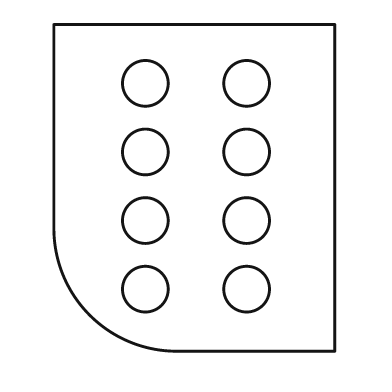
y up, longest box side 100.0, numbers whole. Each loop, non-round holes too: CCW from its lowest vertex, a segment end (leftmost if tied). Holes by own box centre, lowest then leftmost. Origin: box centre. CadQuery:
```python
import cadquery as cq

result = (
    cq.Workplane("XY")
    .moveTo(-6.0, -50.0)
    .lineTo(43.0, -50.0)
    .lineTo(43.0, 50.0)
    .lineTo(-43.0, 50.0)
    .lineTo(-43.0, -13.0)
    .threePointArc((-32.0, -39.0), (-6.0, -50.0))
    .close()
    .moveTo(-15.0, -31.0)
    .circle(7.0)
    .moveTo(16.0, -31.0)
    .circle(7.0)
    .moveTo(-15.0, -10.0)
    .circle(7.0)
    .moveTo(16.0, -10.0)
    .circle(7.0)
    .moveTo(-15.0, 11.0)
    .circle(7.0)
    .moveTo(16.0, 11.0)
    .circle(7.0)
    .moveTo(-15.0, 32.0)
    .circle(7.0)
    .moveTo(16.0, 32.0)
    .circle(7.0)
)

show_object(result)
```